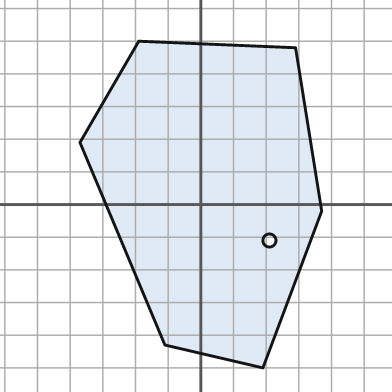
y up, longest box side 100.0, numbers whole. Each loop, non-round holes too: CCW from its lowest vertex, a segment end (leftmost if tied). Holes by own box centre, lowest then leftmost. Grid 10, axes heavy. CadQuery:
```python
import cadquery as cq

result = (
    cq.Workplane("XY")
    .moveTo(19.0, -50.0)
    .lineTo(37.0, -2.0)
    .lineTo(29.0, 48.0)
    .lineTo(-19.0, 50.0)
    .lineTo(-37.0, 19.0)
    .lineTo(-11.0, -43.0)
    .close()
    .moveTo(21.0, -11.0)
    .circle(2.0)
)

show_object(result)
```